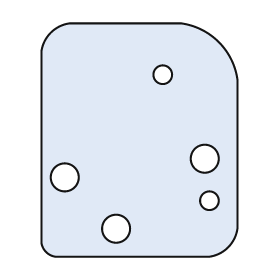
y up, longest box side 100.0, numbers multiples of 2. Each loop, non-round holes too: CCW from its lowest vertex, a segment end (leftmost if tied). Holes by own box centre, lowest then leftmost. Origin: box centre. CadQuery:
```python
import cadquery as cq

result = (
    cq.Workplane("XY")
    .moveTo(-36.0, -50.0)
    .lineTo(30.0, -50.0)
    .threePointArc((38.0, -46.0), (42.0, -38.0))
    .lineTo(42.0, 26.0)
    .threePointArc((34.0, 42.0), (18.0, 50.0))
    .lineTo(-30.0, 50.0)
    .threePointArc((-38.0, 46.0), (-42.0, 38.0))
    .lineTo(-42.0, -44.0)
    .threePointArc((-40.0, -48.0), (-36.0, -50.0))
    .close()
    .moveTo(-10.0, -38.0)
    .circle(6.0)
    .moveTo(30.0, -26.0)
    .circle(4.0)
    .moveTo(-32.0, -16.0)
    .circle(6.0)
    .moveTo(28.0, -8.0)
    .circle(6.0)
    .moveTo(10.0, 28.0)
    .circle(4.0)
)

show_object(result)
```